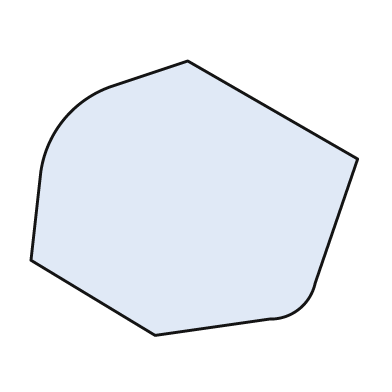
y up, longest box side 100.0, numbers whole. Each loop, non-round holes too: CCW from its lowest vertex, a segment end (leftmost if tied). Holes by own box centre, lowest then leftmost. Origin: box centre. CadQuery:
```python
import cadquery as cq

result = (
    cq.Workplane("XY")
    .moveTo(-12.0, -42.0)
    .lineTo(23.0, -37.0)
    .threePointArc((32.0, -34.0), (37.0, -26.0))
    .lineTo(50.0, 12.0)
    .lineTo(-2.0, 42.0)
    .lineTo(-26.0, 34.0)
    .threePointArc((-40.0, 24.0), (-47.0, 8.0))
    .lineTo(-50.0, -19.0)
    .close()
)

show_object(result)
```